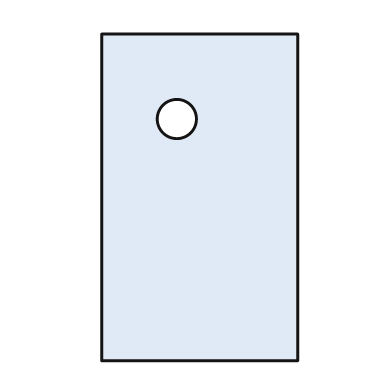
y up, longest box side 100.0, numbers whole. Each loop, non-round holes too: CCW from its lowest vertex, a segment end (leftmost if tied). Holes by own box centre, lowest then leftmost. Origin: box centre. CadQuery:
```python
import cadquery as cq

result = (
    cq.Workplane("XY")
    .moveTo(-30.0, -50.0)
    .lineTo(30.0, -50.0)
    .lineTo(30.0, 50.0)
    .lineTo(-30.0, 50.0)
    .close()
    .moveTo(-7.0, 24.0)
    .circle(6.0)
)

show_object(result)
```